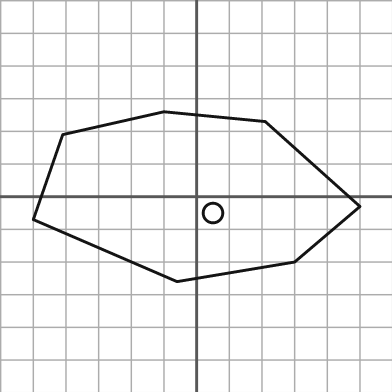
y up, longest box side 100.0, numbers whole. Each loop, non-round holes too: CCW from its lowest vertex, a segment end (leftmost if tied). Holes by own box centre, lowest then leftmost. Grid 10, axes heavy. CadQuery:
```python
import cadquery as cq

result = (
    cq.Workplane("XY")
    .moveTo(-6.0, -26.0)
    .lineTo(30.0, -20.0)
    .lineTo(50.0, -3.0)
    .lineTo(21.0, 23.0)
    .lineTo(-10.0, 26.0)
    .lineTo(-41.0, 19.0)
    .lineTo(-50.0, -7.0)
    .close()
    .moveTo(5.0, -5.0)
    .circle(3.0)
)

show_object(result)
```